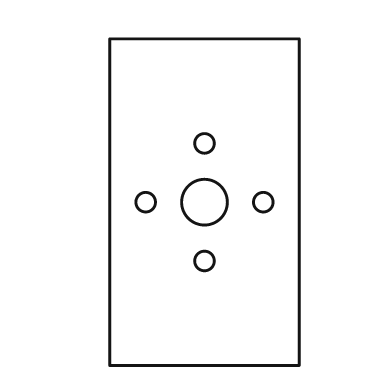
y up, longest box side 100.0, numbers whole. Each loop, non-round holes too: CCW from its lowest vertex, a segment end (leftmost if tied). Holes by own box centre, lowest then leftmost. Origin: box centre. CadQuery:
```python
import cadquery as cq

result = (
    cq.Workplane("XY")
    .moveTo(-29.0, -50.0)
    .lineTo(29.0, -50.0)
    .lineTo(29.0, 50.0)
    .lineTo(-29.0, 50.0)
    .close()
    .moveTo(0.0, -18.0)
    .circle(3.0)
    .moveTo(-18.0, 0.0)
    .circle(3.0)
    .moveTo(0.0, 0.0)
    .circle(7.0)
    .moveTo(18.0, 0.0)
    .circle(3.0)
    .moveTo(0.0, 18.0)
    .circle(3.0)
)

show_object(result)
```